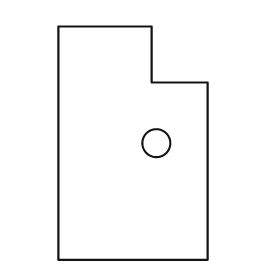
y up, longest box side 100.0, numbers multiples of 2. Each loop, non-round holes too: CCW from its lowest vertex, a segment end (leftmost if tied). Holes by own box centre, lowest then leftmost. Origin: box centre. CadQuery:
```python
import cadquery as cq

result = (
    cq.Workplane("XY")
    .moveTo(-32.0, -50.0)
    .lineTo(32.0, -50.0)
    .lineTo(32.0, 26.0)
    .lineTo(8.0, 26.0)
    .lineTo(8.0, 50.0)
    .lineTo(-32.0, 50.0)
    .close()
    .moveTo(10.0, 0.0)
    .circle(6.0)
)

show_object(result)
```